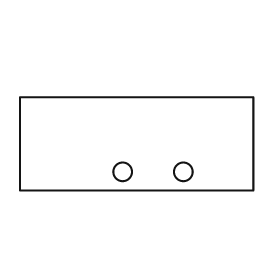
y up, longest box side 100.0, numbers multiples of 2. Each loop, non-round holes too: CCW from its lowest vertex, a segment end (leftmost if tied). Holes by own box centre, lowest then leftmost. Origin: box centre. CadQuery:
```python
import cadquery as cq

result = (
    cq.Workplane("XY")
    .moveTo(-50.0, -20.0)
    .lineTo(50.0, -20.0)
    .lineTo(50.0, 20.0)
    .lineTo(-50.0, 20.0)
    .close()
    .moveTo(-6.0, -12.0)
    .circle(4.0)
    .moveTo(20.0, -12.0)
    .circle(4.0)
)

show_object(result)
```